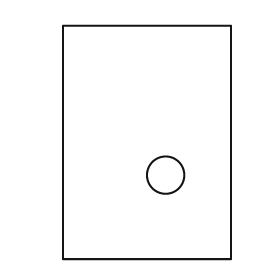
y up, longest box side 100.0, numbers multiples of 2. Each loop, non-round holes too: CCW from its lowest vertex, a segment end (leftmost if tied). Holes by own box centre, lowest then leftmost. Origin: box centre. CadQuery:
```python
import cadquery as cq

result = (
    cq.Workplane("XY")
    .moveTo(-36.0, -50.0)
    .lineTo(36.0, -50.0)
    .lineTo(36.0, 50.0)
    .lineTo(-36.0, 50.0)
    .close()
    .moveTo(8.0, -14.0)
    .circle(8.0)
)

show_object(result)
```